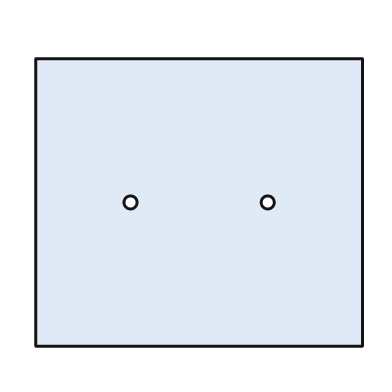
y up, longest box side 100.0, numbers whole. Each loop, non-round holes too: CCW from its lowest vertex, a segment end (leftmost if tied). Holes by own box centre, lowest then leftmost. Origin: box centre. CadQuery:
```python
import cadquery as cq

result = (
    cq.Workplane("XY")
    .moveTo(-50.0, -44.0)
    .lineTo(50.0, -44.0)
    .lineTo(50.0, 44.0)
    .lineTo(-50.0, 44.0)
    .close()
    .moveTo(-21.0, 0.0)
    .circle(2.0)
    .moveTo(21.0, 0.0)
    .circle(2.0)
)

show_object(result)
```